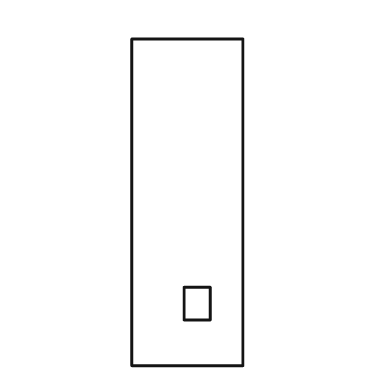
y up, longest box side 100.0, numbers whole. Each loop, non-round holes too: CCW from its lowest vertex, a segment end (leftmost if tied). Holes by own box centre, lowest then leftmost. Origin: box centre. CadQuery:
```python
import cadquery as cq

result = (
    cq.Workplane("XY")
    .moveTo(-17.0, -50.0)
    .lineTo(17.0, -50.0)
    .lineTo(17.0, 50.0)
    .lineTo(-17.0, 50.0)
    .close()
    .moveTo(-1.0, -36.0)
    .lineTo(7.0, -36.0)
    .lineTo(7.0, -26.0)
    .lineTo(-1.0, -26.0)
    .close()
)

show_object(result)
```